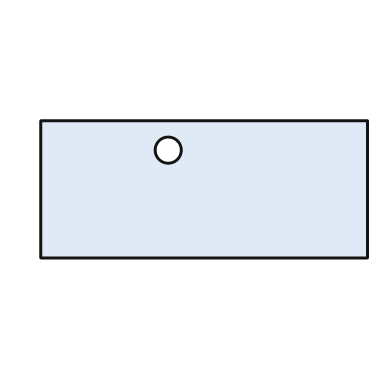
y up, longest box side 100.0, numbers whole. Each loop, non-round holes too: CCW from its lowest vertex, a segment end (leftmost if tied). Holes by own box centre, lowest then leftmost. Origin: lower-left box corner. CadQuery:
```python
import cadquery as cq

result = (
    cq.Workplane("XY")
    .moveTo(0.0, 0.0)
    .lineTo(100.0, 0.0)
    .lineTo(100.0, 42.0)
    .lineTo(0.0, 42.0)
    .close()
    .moveTo(39.0, 33.0)
    .circle(4.0)
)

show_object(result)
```